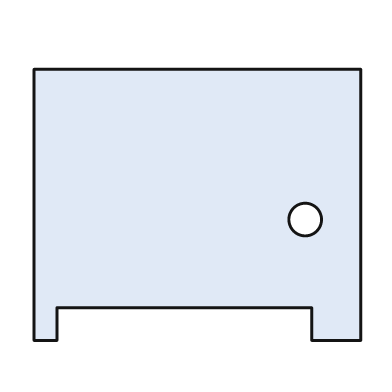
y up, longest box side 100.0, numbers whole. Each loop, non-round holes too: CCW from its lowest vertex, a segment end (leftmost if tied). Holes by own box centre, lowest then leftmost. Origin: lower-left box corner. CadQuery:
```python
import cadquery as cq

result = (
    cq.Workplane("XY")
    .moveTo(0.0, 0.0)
    .lineTo(7.0, 0.0)
    .lineTo(7.0, 10.0)
    .lineTo(85.0, 10.0)
    .lineTo(85.0, 0.0)
    .lineTo(100.0, 0.0)
    .lineTo(100.0, 83.0)
    .lineTo(0.0, 83.0)
    .close()
    .moveTo(83.0, 37.0)
    .circle(5.0)
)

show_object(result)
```